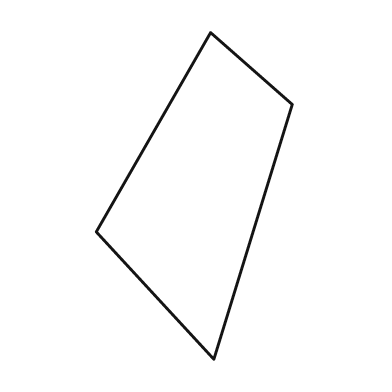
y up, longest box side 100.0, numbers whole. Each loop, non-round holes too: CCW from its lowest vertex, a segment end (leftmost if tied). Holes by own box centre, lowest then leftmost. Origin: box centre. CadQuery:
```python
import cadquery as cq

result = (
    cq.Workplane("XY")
    .moveTo(6.0, -50.0)
    .lineTo(30.0, 28.0)
    .lineTo(5.0, 50.0)
    .lineTo(-30.0, -11.0)
    .close()
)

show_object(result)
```